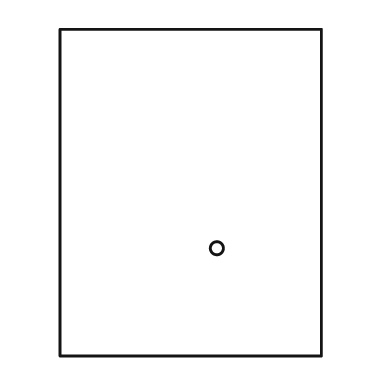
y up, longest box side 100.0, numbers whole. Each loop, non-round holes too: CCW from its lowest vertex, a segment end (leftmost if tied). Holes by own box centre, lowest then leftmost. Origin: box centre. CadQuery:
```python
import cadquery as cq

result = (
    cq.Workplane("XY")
    .moveTo(-40.0, -50.0)
    .lineTo(40.0, -50.0)
    .lineTo(40.0, 50.0)
    .lineTo(-40.0, 50.0)
    .close()
    .moveTo(8.0, -17.0)
    .circle(2.0)
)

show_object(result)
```